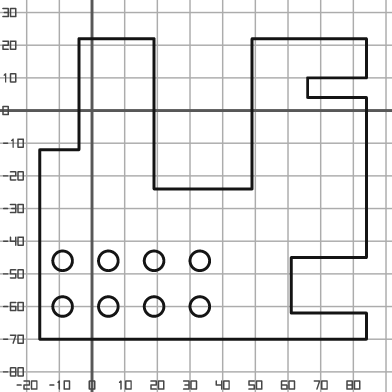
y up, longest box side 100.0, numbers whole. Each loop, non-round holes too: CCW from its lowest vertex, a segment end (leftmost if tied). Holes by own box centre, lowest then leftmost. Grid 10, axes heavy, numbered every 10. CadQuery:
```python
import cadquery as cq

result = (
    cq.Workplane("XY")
    .moveTo(-16.0, -70.0)
    .lineTo(84.0, -70.0)
    .lineTo(84.0, -62.0)
    .lineTo(61.0, -62.0)
    .lineTo(61.0, -45.0)
    .lineTo(84.0, -45.0)
    .lineTo(84.0, 4.0)
    .lineTo(66.0, 4.0)
    .lineTo(66.0, 10.0)
    .lineTo(84.0, 10.0)
    .lineTo(84.0, 22.0)
    .lineTo(49.0, 22.0)
    .lineTo(49.0, -24.0)
    .lineTo(19.0, -24.0)
    .lineTo(19.0, 22.0)
    .lineTo(-4.0, 22.0)
    .lineTo(-4.0, -12.0)
    .lineTo(-16.0, -12.0)
    .close()
    .moveTo(-9.0, -60.0)
    .circle(3.0)
    .moveTo(5.0, -60.0)
    .circle(3.0)
    .moveTo(19.0, -60.0)
    .circle(3.0)
    .moveTo(33.0, -60.0)
    .circle(3.0)
    .moveTo(-9.0, -46.0)
    .circle(3.0)
    .moveTo(5.0, -46.0)
    .circle(3.0)
    .moveTo(19.0, -46.0)
    .circle(3.0)
    .moveTo(33.0, -46.0)
    .circle(3.0)
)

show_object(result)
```